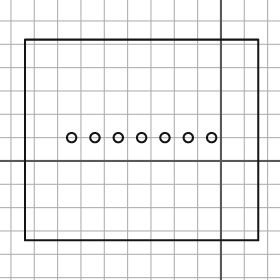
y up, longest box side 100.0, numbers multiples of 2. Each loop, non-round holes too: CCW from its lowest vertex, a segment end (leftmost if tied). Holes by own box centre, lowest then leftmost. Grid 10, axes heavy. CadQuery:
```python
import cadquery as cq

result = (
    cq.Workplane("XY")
    .moveTo(-84.0, -34.0)
    .lineTo(16.0, -34.0)
    .lineTo(16.0, 52.0)
    .lineTo(-84.0, 52.0)
    .close()
    .moveTo(-64.0, 10.0)
    .circle(2.0)
    .moveTo(-54.0, 10.0)
    .circle(2.0)
    .moveTo(-44.0, 10.0)
    .circle(2.0)
    .moveTo(-34.0, 10.0)
    .circle(2.0)
    .moveTo(-24.0, 10.0)
    .circle(2.0)
    .moveTo(-14.0, 10.0)
    .circle(2.0)
    .moveTo(-4.0, 10.0)
    .circle(2.0)
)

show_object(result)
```